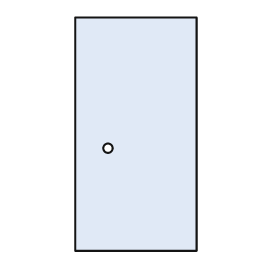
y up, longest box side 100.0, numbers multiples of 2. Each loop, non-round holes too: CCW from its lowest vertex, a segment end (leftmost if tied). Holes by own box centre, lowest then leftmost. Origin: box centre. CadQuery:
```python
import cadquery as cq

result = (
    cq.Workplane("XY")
    .moveTo(-26.0, -50.0)
    .lineTo(26.0, -50.0)
    .lineTo(26.0, 50.0)
    .lineTo(-26.0, 50.0)
    .close()
    .moveTo(-12.0, -6.0)
    .circle(2.0)
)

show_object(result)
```